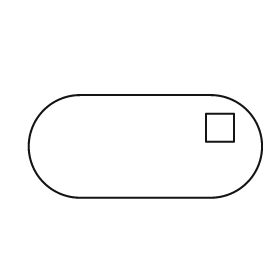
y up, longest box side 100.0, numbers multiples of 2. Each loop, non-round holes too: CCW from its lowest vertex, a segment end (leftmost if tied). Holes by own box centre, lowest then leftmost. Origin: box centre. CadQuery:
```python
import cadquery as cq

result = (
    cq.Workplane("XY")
    .moveTo(-28.0, -22.0)
    .lineTo(28.0, -22.0)
    .threePointArc((50.0, 0.0), (28.0, 22.0))
    .lineTo(-28.0, 22.0)
    .threePointArc((-50.0, 0.0), (-28.0, -22.0))
    .close()
    .moveTo(26.0, 2.0)
    .lineTo(38.0, 2.0)
    .lineTo(38.0, 14.0)
    .lineTo(26.0, 14.0)
    .close()
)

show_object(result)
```